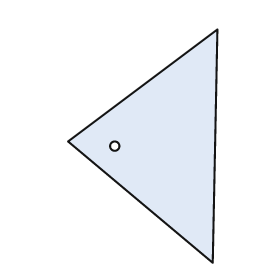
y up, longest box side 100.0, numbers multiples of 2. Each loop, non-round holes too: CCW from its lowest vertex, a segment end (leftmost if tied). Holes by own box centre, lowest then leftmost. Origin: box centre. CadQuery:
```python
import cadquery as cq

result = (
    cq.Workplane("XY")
    .moveTo(30.0, -50.0)
    .lineTo(32.0, 50.0)
    .lineTo(-32.0, 2.0)
    .close()
    .moveTo(-12.0, 0.0)
    .circle(2.0)
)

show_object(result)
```